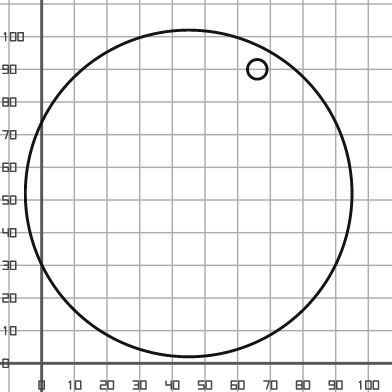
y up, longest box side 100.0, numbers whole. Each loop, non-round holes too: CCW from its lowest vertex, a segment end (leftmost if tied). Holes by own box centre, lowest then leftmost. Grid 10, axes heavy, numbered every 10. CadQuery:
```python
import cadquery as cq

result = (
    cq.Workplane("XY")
    .moveTo(45.0, 52.0)
    .circle(50.0)
    .moveTo(66.0, 90.0)
    .circle(3.0)
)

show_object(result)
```